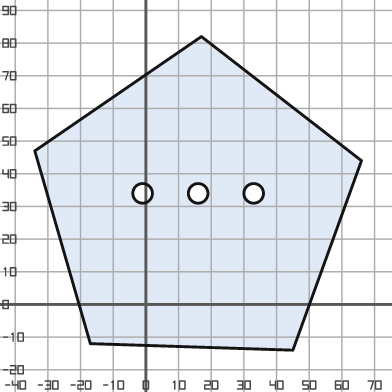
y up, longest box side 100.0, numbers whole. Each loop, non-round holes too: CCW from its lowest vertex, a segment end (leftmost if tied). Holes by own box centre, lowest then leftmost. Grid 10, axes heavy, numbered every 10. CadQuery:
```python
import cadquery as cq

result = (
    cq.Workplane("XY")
    .moveTo(45.0, -14.0)
    .lineTo(66.0, 44.0)
    .lineTo(17.0, 82.0)
    .lineTo(-34.0, 47.0)
    .lineTo(-17.0, -12.0)
    .close()
    .moveTo(-1.0, 34.0)
    .circle(3.0)
    .moveTo(16.0, 34.0)
    .circle(3.0)
    .moveTo(33.0, 34.0)
    .circle(3.0)
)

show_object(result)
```